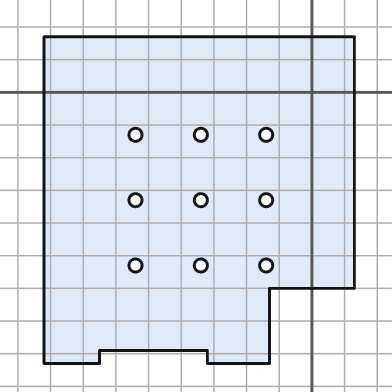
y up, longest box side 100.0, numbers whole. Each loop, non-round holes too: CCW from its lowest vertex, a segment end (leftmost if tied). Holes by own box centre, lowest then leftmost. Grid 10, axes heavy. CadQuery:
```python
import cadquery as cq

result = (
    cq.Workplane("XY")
    .moveTo(-82.0, -83.0)
    .lineTo(-65.0, -83.0)
    .lineTo(-65.0, -79.0)
    .lineTo(-32.0, -79.0)
    .lineTo(-32.0, -83.0)
    .lineTo(-13.0, -83.0)
    .lineTo(-13.0, -60.0)
    .lineTo(13.0, -60.0)
    .lineTo(13.0, 17.0)
    .lineTo(-82.0, 17.0)
    .close()
    .moveTo(-54.0, -53.0)
    .circle(2.0)
    .moveTo(-34.0, -53.0)
    .circle(2.0)
    .moveTo(-14.0, -53.0)
    .circle(2.0)
    .moveTo(-54.0, -33.0)
    .circle(2.0)
    .moveTo(-34.0, -33.0)
    .circle(2.0)
    .moveTo(-14.0, -33.0)
    .circle(2.0)
    .moveTo(-54.0, -13.0)
    .circle(2.0)
    .moveTo(-34.0, -13.0)
    .circle(2.0)
    .moveTo(-14.0, -13.0)
    .circle(2.0)
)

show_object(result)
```